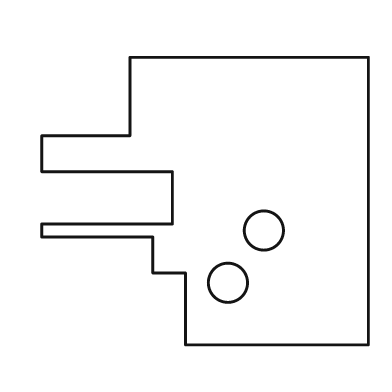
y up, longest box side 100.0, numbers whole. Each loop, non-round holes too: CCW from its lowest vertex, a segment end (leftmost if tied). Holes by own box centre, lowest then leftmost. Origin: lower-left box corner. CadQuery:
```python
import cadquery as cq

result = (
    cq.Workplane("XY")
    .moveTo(44.0, 0.0)
    .lineTo(100.0, 0.0)
    .lineTo(100.0, 88.0)
    .lineTo(27.0, 88.0)
    .lineTo(27.0, 64.0)
    .lineTo(0.0, 64.0)
    .lineTo(0.0, 53.0)
    .lineTo(40.0, 53.0)
    .lineTo(40.0, 37.0)
    .lineTo(0.0, 37.0)
    .lineTo(0.0, 33.0)
    .lineTo(34.0, 33.0)
    .lineTo(34.0, 22.0)
    .lineTo(44.0, 22.0)
    .close()
    .moveTo(57.0, 19.0)
    .circle(6.0)
    .moveTo(68.0, 35.0)
    .circle(6.0)
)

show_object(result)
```